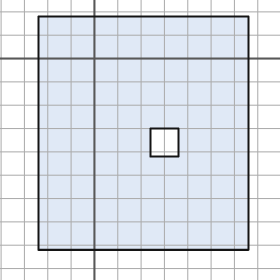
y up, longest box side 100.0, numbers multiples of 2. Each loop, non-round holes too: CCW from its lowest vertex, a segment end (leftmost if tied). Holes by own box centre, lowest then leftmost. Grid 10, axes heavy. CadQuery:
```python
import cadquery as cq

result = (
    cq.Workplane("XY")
    .moveTo(-24.0, -82.0)
    .lineTo(66.0, -82.0)
    .lineTo(66.0, 18.0)
    .lineTo(-24.0, 18.0)
    .close()
    .moveTo(24.0, -42.0)
    .lineTo(36.0, -42.0)
    .lineTo(36.0, -30.0)
    .lineTo(24.0, -30.0)
    .close()
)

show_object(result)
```